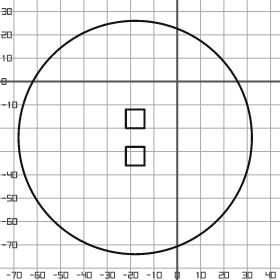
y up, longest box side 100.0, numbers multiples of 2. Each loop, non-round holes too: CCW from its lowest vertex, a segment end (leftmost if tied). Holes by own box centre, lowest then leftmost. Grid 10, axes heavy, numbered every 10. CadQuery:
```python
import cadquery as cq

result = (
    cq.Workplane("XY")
    .moveTo(-18.0, -24.0)
    .circle(50.0)
    .moveTo(-22.0, -36.0)
    .lineTo(-14.0, -36.0)
    .lineTo(-14.0, -28.0)
    .lineTo(-22.0, -28.0)
    .close()
    .moveTo(-22.0, -20.0)
    .lineTo(-14.0, -20.0)
    .lineTo(-14.0, -12.0)
    .lineTo(-22.0, -12.0)
    .close()
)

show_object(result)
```